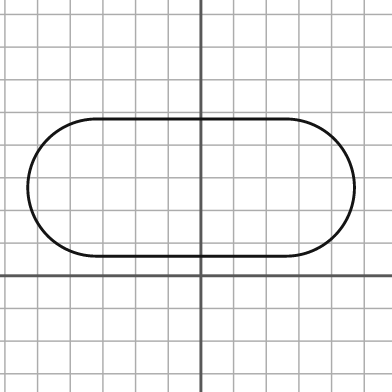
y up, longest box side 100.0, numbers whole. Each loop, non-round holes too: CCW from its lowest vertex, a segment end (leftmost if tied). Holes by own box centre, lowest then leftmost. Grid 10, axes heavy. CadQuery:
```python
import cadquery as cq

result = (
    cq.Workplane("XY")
    .moveTo(-32.0, 6.0)
    .lineTo(26.0, 6.0)
    .threePointArc((47.0, 27.0), (26.0, 48.0))
    .lineTo(-32.0, 48.0)
    .threePointArc((-53.0, 27.0), (-32.0, 6.0))
    .close()
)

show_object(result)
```